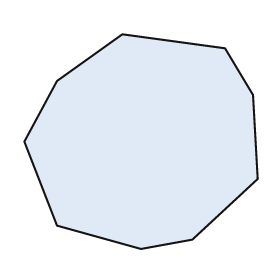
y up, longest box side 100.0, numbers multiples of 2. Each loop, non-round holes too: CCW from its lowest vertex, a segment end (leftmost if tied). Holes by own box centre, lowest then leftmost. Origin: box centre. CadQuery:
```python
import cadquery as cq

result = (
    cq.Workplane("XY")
    .moveTo(0.0, -46.0)
    .lineTo(22.0, -42.0)
    .lineTo(50.0, -16.0)
    .lineTo(48.0, 20.0)
    .lineTo(36.0, 40.0)
    .lineTo(-8.0, 46.0)
    .lineTo(-36.0, 26.0)
    .lineTo(-50.0, 0.0)
    .lineTo(-36.0, -36.0)
    .close()
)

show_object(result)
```